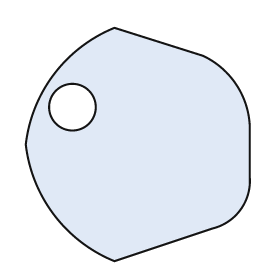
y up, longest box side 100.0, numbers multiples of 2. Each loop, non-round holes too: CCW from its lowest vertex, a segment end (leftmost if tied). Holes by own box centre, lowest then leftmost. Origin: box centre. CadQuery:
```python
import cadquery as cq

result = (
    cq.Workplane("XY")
    .moveTo(-10.0, -50.0)
    .lineTo(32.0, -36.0)
    .threePointArc((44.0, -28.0), (48.0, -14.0))
    .lineTo(48.0, 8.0)
    .threePointArc((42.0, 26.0), (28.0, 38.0))
    .lineTo(-10.0, 50.0)
    .threePointArc((-36.0, 30.0), (-48.0, 0.0))
    .threePointArc((-36.0, -30.0), (-10.0, -50.0))
    .close()
    .moveTo(-28.0, 16.0)
    .circle(10.0)
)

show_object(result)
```